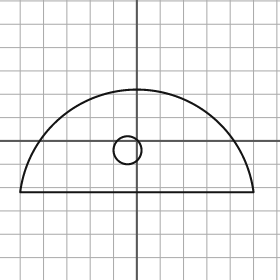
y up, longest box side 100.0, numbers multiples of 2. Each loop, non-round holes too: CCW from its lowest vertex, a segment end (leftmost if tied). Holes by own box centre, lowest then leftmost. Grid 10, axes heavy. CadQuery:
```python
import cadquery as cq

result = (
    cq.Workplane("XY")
    .moveTo(-50.0, -22.0)
    .lineTo(50.0, -22.0)
    .threePointArc((0.0, 22.0), (-50.0, -22.0))
    .close()
    .moveTo(-4.0, -4.0)
    .circle(6.0)
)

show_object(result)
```